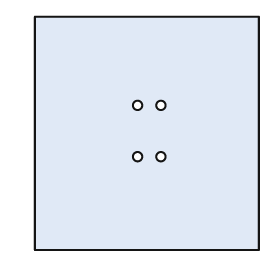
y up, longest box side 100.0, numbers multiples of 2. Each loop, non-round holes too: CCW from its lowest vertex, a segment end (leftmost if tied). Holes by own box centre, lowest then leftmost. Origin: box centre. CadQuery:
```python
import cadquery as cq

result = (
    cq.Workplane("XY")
    .moveTo(-48.0, -50.0)
    .lineTo(48.0, -50.0)
    .lineTo(48.0, 50.0)
    .lineTo(-48.0, 50.0)
    .close()
    .moveTo(-4.0, -10.0)
    .circle(2.0)
    .moveTo(6.0, -10.0)
    .circle(2.0)
    .moveTo(-4.0, 12.0)
    .circle(2.0)
    .moveTo(6.0, 12.0)
    .circle(2.0)
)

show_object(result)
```